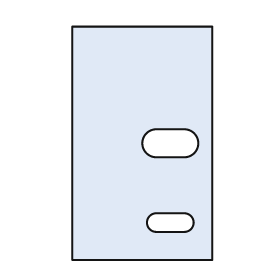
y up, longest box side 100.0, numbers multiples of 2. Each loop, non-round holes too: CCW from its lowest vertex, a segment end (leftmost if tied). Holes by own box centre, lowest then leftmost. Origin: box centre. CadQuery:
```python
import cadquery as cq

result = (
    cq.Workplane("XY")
    .moveTo(-30.0, -50.0)
    .lineTo(30.0, -50.0)
    .lineTo(30.0, 50.0)
    .lineTo(-30.0, 50.0)
    .close()
    .moveTo(6.0, -38.0)
    .lineTo(18.0, -38.0)
    .threePointArc((22.0, -34.0), (18.0, -30.0))
    .lineTo(6.0, -30.0)
    .threePointArc((2.0, -34.0), (6.0, -38.0))
    .close()
    .moveTo(6.0, -6.0)
    .lineTo(18.0, -6.0)
    .threePointArc((24.0, 0.0), (18.0, 6.0))
    .lineTo(6.0, 6.0)
    .threePointArc((0.0, 0.0), (6.0, -6.0))
    .close()
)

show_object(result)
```